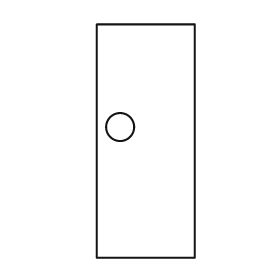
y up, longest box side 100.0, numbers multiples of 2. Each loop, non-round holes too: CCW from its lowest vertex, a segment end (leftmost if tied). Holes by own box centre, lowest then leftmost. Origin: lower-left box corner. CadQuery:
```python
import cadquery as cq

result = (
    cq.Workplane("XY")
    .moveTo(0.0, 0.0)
    .lineTo(42.0, 0.0)
    .lineTo(42.0, 100.0)
    .lineTo(0.0, 100.0)
    .close()
    .moveTo(10.0, 56.0)
    .circle(6.0)
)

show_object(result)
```